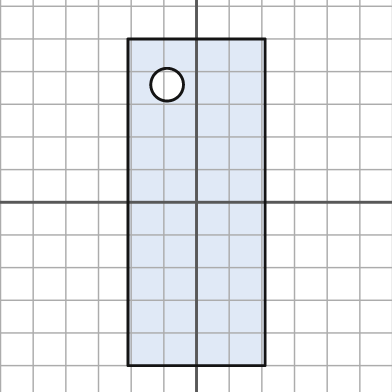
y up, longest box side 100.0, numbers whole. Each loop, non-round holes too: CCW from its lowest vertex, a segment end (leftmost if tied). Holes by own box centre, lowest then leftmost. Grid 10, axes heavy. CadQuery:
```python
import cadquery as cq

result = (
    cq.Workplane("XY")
    .moveTo(-21.0, -50.0)
    .lineTo(21.0, -50.0)
    .lineTo(21.0, 50.0)
    .lineTo(-21.0, 50.0)
    .close()
    .moveTo(-9.0, 36.0)
    .circle(5.0)
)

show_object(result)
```